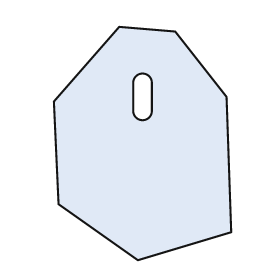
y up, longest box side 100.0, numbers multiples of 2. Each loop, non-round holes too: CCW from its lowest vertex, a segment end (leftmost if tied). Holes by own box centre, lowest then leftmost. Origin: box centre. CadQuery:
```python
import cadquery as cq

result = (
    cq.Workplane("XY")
    .moveTo(-2.0, -50.0)
    .lineTo(38.0, -38.0)
    .lineTo(36.0, 20.0)
    .lineTo(14.0, 48.0)
    .lineTo(-10.0, 50.0)
    .lineTo(-38.0, 18.0)
    .lineTo(-36.0, -26.0)
    .close()
    .moveTo(-4.0, 14.0)
    .threePointArc((0.0, 10.0), (4.0, 14.0))
    .lineTo(4.0, 26.0)
    .threePointArc((0.0, 30.0), (-4.0, 26.0))
    .close()
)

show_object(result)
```